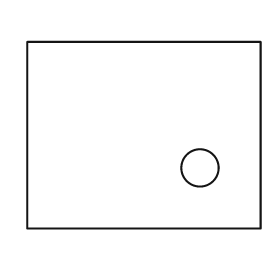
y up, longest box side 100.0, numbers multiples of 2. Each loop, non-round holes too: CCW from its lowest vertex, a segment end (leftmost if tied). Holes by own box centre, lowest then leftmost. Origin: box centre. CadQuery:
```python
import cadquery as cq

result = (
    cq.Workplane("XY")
    .moveTo(-50.0, -40.0)
    .lineTo(50.0, -40.0)
    .lineTo(50.0, 40.0)
    .lineTo(-50.0, 40.0)
    .close()
    .moveTo(24.0, -14.0)
    .circle(8.0)
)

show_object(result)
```